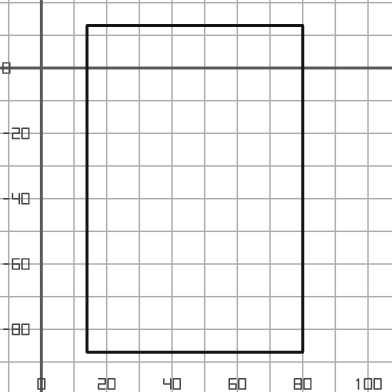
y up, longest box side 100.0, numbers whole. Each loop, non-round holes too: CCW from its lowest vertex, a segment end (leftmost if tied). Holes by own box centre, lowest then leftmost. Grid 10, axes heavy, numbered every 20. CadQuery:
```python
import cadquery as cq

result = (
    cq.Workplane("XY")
    .moveTo(14.0, -87.0)
    .lineTo(80.0, -87.0)
    .lineTo(80.0, 13.0)
    .lineTo(14.0, 13.0)
    .close()
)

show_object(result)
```